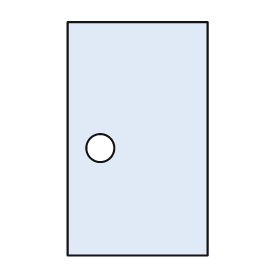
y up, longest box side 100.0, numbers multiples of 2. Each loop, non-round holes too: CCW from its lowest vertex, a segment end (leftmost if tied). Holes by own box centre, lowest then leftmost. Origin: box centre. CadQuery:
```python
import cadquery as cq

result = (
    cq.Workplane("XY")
    .moveTo(-30.0, -50.0)
    .lineTo(30.0, -50.0)
    .lineTo(30.0, 50.0)
    .lineTo(-30.0, 50.0)
    .close()
    .moveTo(-16.0, -4.0)
    .circle(6.0)
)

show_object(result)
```